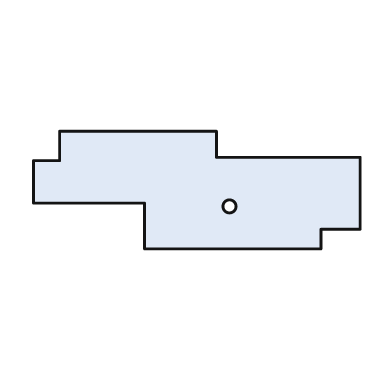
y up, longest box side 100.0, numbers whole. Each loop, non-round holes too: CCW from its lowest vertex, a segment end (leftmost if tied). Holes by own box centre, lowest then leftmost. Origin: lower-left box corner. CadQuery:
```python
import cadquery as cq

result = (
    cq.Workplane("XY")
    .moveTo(34.0, 0.0)
    .lineTo(88.0, 0.0)
    .lineTo(88.0, 6.0)
    .lineTo(100.0, 6.0)
    .lineTo(100.0, 28.0)
    .lineTo(56.0, 28.0)
    .lineTo(56.0, 36.0)
    .lineTo(8.0, 36.0)
    .lineTo(8.0, 27.0)
    .lineTo(0.0, 27.0)
    .lineTo(0.0, 14.0)
    .lineTo(34.0, 14.0)
    .close()
    .moveTo(60.0, 13.0)
    .circle(2.0)
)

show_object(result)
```